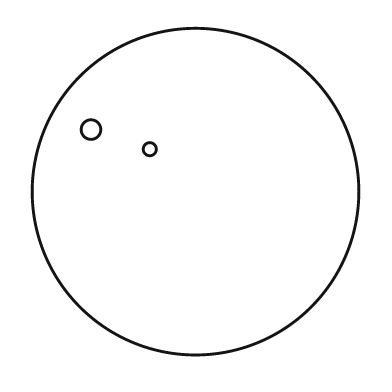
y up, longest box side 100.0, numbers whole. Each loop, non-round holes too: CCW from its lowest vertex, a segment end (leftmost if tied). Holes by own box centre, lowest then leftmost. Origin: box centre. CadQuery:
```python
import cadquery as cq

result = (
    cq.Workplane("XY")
    .moveTo(0.0, 0.0)
    .circle(50.0)
    .moveTo(-14.0, 13.0)
    .circle(2.0)
    .moveTo(-32.0, 19.0)
    .circle(3.0)
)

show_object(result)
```